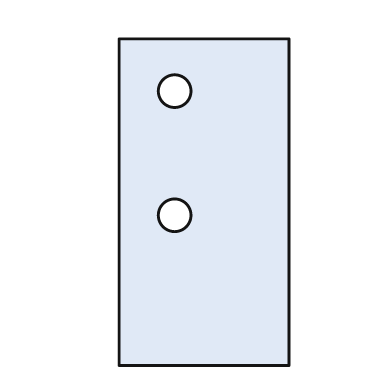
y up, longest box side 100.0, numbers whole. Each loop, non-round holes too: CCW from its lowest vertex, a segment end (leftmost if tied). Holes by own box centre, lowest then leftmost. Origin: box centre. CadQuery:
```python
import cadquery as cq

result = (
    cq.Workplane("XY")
    .moveTo(-26.0, -50.0)
    .lineTo(26.0, -50.0)
    .lineTo(26.0, 50.0)
    .lineTo(-26.0, 50.0)
    .close()
    .moveTo(-9.0, -4.0)
    .circle(5.0)
    .moveTo(-9.0, 34.0)
    .circle(5.0)
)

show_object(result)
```